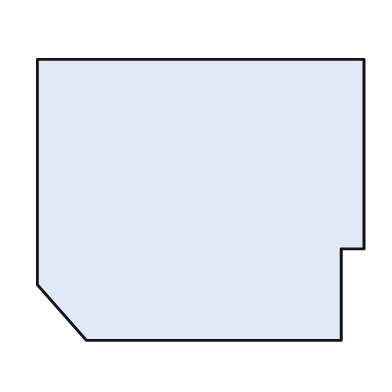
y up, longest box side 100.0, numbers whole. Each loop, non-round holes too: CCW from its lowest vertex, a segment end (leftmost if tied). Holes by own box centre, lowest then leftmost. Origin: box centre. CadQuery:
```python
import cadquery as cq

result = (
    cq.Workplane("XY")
    .moveTo(-35.0, -43.0)
    .lineTo(43.0, -43.0)
    .lineTo(43.0, -15.0)
    .lineTo(50.0, -15.0)
    .lineTo(50.0, 43.0)
    .lineTo(-50.0, 43.0)
    .lineTo(-50.0, -26.0)
    .close()
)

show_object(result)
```